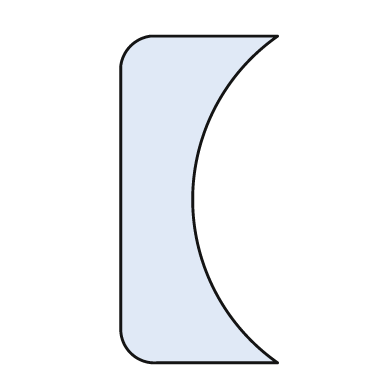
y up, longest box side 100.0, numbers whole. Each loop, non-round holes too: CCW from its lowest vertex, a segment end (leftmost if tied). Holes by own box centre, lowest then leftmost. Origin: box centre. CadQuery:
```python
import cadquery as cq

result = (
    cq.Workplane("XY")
    .moveTo(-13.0, -50.0)
    .lineTo(24.0, -50.0)
    .threePointArc((-2.0, 0.0), (24.0, 50.0))
    .lineTo(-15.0, 50.0)
    .threePointArc((-21.0, 47.0), (-24.0, 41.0))
    .lineTo(-24.0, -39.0)
    .threePointArc((-21.0, -47.0), (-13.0, -50.0))
    .close()
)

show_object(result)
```